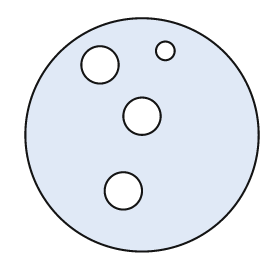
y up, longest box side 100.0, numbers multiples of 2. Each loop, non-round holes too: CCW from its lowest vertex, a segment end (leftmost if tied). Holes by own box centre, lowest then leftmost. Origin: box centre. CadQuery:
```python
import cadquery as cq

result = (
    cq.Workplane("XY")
    .moveTo(0.0, 0.0)
    .circle(50.0)
    .moveTo(-8.0, -24.0)
    .circle(8.0)
    .moveTo(0.0, 8.0)
    .circle(8.0)
    .moveTo(-18.0, 30.0)
    .circle(8.0)
    .moveTo(10.0, 36.0)
    .circle(4.0)
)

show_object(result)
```